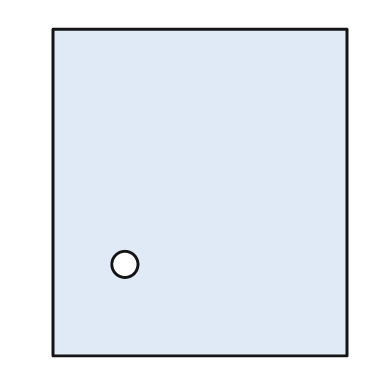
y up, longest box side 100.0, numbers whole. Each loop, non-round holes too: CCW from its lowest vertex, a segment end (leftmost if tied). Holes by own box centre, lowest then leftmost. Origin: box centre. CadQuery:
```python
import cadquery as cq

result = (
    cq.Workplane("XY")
    .moveTo(-45.0, -50.0)
    .lineTo(45.0, -50.0)
    .lineTo(45.0, 50.0)
    .lineTo(-45.0, 50.0)
    .close()
    .moveTo(-23.0, -22.0)
    .circle(4.0)
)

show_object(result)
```